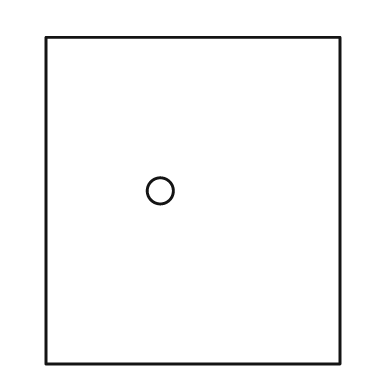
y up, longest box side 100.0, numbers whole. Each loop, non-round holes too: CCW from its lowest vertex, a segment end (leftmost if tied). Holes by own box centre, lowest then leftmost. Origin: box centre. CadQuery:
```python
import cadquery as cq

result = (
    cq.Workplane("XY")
    .moveTo(-45.0, -50.0)
    .lineTo(45.0, -50.0)
    .lineTo(45.0, 50.0)
    .lineTo(-45.0, 50.0)
    .close()
    .moveTo(-10.0, 3.0)
    .circle(4.0)
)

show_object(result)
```